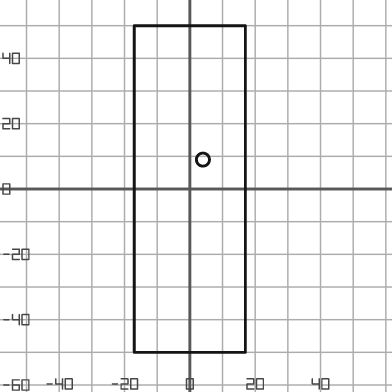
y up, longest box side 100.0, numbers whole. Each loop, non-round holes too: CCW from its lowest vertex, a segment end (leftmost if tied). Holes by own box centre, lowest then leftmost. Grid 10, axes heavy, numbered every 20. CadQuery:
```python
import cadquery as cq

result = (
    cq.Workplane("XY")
    .moveTo(-17.0, -50.0)
    .lineTo(17.0, -50.0)
    .lineTo(17.0, 50.0)
    .lineTo(-17.0, 50.0)
    .close()
    .moveTo(4.0, 9.0)
    .circle(2.0)
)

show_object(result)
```